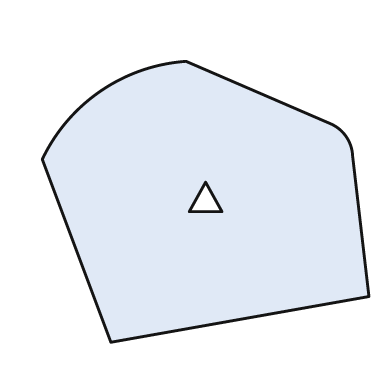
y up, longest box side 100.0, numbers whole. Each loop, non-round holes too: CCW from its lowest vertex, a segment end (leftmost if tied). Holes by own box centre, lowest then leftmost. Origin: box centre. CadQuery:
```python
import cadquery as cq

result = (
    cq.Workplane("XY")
    .moveTo(-29.0, -43.0)
    .lineTo(50.0, -29.0)
    .lineTo(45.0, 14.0)
    .threePointArc((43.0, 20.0), (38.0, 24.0))
    .lineTo(-6.0, 43.0)
    .threePointArc((-32.0, 34.0), (-50.0, 13.0))
    .close()
    .moveTo(-5.0, -3.0)
    .lineTo(5.0, -3.0)
    .lineTo(0.0, 6.0)
    .close()
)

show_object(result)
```